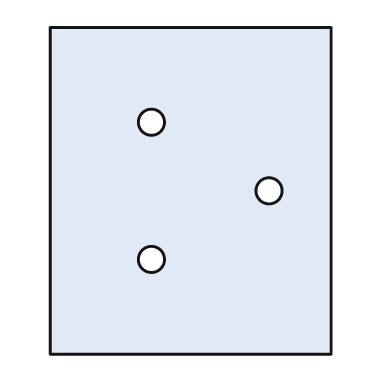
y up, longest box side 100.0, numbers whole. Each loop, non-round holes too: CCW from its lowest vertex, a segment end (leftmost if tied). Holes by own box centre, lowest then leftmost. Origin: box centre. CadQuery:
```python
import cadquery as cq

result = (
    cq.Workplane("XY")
    .moveTo(-43.0, -50.0)
    .lineTo(43.0, -50.0)
    .lineTo(43.0, 50.0)
    .lineTo(-43.0, 50.0)
    .close()
    .moveTo(-12.0, -21.0)
    .circle(4.0)
    .moveTo(24.0, 0.0)
    .circle(4.0)
    .moveTo(-12.0, 21.0)
    .circle(4.0)
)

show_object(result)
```